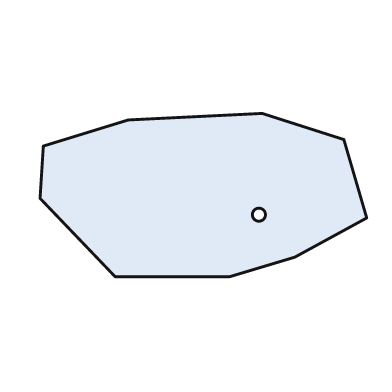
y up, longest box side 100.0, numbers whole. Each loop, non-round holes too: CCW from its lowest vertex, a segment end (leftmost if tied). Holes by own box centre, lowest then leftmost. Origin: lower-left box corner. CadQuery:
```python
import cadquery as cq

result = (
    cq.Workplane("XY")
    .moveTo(23.0, 0.0)
    .lineTo(58.0, 0.0)
    .lineTo(78.0, 6.0)
    .lineTo(100.0, 18.0)
    .lineTo(93.0, 42.0)
    .lineTo(68.0, 50.0)
    .lineTo(27.0, 48.0)
    .lineTo(1.0, 40.0)
    .lineTo(0.0, 24.0)
    .close()
    .moveTo(67.0, 19.0)
    .circle(2.0)
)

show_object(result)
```